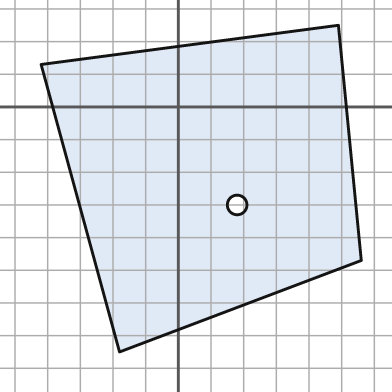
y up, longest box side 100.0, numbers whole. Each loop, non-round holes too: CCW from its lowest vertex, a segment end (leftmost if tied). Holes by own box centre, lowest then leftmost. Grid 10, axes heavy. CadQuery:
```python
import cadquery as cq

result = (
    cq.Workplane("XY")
    .moveTo(-18.0, -75.0)
    .lineTo(56.0, -47.0)
    .lineTo(49.0, 25.0)
    .lineTo(-42.0, 13.0)
    .close()
    .moveTo(18.0, -30.0)
    .circle(3.0)
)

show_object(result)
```